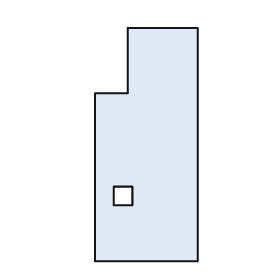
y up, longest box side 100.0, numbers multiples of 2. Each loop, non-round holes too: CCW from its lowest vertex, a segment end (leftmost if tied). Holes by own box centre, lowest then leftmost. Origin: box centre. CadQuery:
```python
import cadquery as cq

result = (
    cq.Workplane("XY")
    .moveTo(-22.0, -50.0)
    .lineTo(22.0, -50.0)
    .lineTo(22.0, 50.0)
    .lineTo(-8.0, 50.0)
    .lineTo(-8.0, 22.0)
    .lineTo(-22.0, 22.0)
    .close()
    .moveTo(-14.0, -26.0)
    .lineTo(-6.0, -26.0)
    .lineTo(-6.0, -18.0)
    .lineTo(-14.0, -18.0)
    .close()
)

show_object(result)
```